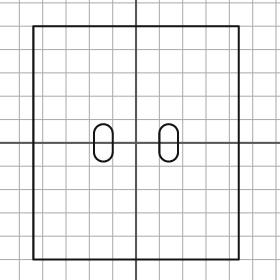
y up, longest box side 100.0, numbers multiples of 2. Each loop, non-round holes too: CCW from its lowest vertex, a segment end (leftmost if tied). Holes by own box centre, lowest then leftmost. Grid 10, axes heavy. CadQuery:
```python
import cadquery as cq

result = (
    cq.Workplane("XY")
    .moveTo(-44.0, -50.0)
    .lineTo(44.0, -50.0)
    .lineTo(44.0, 50.0)
    .lineTo(-44.0, 50.0)
    .close()
    .moveTo(-18.0, -4.0)
    .threePointArc((-14.0, -8.0), (-10.0, -4.0))
    .lineTo(-10.0, 4.0)
    .threePointArc((-14.0, 8.0), (-18.0, 4.0))
    .close()
    .moveTo(10.0, -4.0)
    .threePointArc((14.0, -8.0), (18.0, -4.0))
    .lineTo(18.0, 4.0)
    .threePointArc((14.0, 8.0), (10.0, 4.0))
    .close()
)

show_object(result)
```